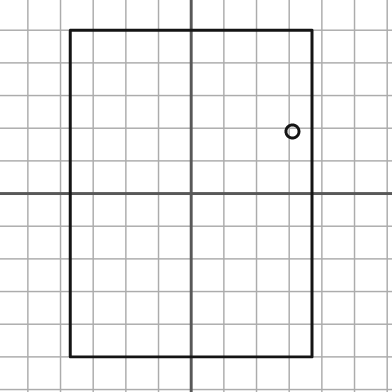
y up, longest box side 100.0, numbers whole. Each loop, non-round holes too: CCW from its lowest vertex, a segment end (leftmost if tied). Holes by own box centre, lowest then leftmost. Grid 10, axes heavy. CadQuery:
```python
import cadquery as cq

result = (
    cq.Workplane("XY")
    .moveTo(-37.0, -50.0)
    .lineTo(37.0, -50.0)
    .lineTo(37.0, 50.0)
    .lineTo(-37.0, 50.0)
    .close()
    .moveTo(31.0, 19.0)
    .circle(2.0)
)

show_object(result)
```